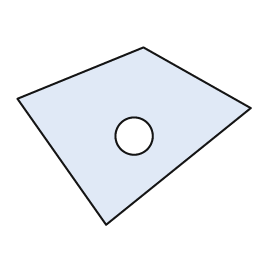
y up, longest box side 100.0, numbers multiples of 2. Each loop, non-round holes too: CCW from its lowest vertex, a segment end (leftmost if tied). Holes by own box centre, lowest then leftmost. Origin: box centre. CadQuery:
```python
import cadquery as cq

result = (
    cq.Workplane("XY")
    .moveTo(-12.0, -38.0)
    .lineTo(50.0, 12.0)
    .lineTo(4.0, 38.0)
    .lineTo(-50.0, 16.0)
    .close()
    .moveTo(0.0, 0.0)
    .circle(8.0)
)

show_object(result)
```